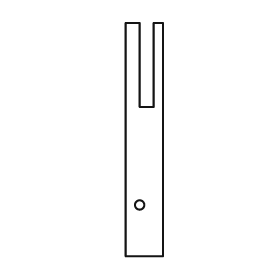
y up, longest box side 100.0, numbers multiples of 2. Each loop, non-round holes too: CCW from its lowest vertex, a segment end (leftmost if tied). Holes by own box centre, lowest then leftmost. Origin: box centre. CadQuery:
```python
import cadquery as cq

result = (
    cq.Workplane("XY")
    .moveTo(-8.0, -50.0)
    .lineTo(8.0, -50.0)
    .lineTo(8.0, 50.0)
    .lineTo(4.0, 50.0)
    .lineTo(4.0, 14.0)
    .lineTo(-2.0, 14.0)
    .lineTo(-2.0, 50.0)
    .lineTo(-8.0, 50.0)
    .close()
    .moveTo(-2.0, -28.0)
    .circle(2.0)
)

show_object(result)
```